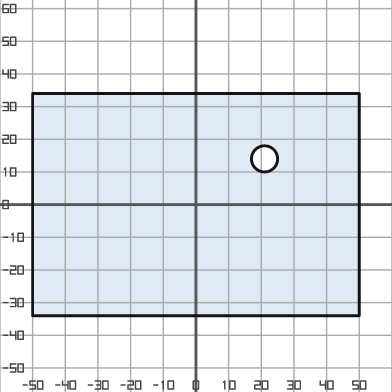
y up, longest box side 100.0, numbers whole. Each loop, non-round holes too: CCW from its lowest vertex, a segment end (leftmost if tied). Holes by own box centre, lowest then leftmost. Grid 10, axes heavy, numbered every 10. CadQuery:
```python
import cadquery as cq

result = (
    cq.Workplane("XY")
    .moveTo(-50.0, -34.0)
    .lineTo(50.0, -34.0)
    .lineTo(50.0, 34.0)
    .lineTo(-50.0, 34.0)
    .close()
    .moveTo(21.0, 14.0)
    .circle(4.0)
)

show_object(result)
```